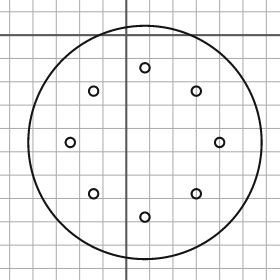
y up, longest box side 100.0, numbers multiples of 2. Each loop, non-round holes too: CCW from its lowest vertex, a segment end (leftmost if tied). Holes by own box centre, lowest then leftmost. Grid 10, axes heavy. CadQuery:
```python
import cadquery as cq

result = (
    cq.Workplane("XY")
    .moveTo(8.0, -46.0)
    .circle(50.0)
    .moveTo(8.0, -78.0)
    .circle(2.0)
    .moveTo(-14.0, -68.0)
    .circle(2.0)
    .moveTo(30.0, -68.0)
    .circle(2.0)
    .moveTo(-24.0, -46.0)
    .circle(2.0)
    .moveTo(40.0, -46.0)
    .circle(2.0)
    .moveTo(-14.0, -24.0)
    .circle(2.0)
    .moveTo(30.0, -24.0)
    .circle(2.0)
    .moveTo(8.0, -14.0)
    .circle(2.0)
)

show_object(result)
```